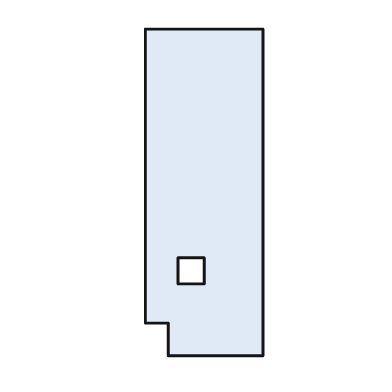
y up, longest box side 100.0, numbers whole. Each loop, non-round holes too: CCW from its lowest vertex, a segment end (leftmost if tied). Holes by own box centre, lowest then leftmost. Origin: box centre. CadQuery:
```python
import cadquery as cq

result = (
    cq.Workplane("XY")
    .moveTo(-11.0, -50.0)
    .lineTo(18.0, -50.0)
    .lineTo(18.0, 50.0)
    .lineTo(-18.0, 50.0)
    .lineTo(-18.0, -40.0)
    .lineTo(-11.0, -40.0)
    .close()
    .moveTo(-8.0, -28.0)
    .lineTo(0.0, -28.0)
    .lineTo(0.0, -20.0)
    .lineTo(-8.0, -20.0)
    .close()
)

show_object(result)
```